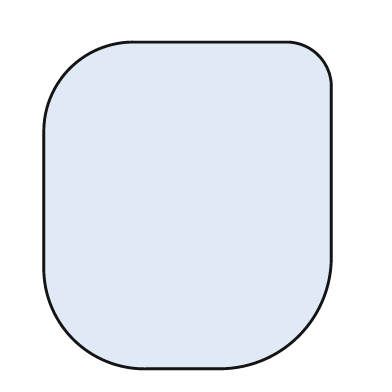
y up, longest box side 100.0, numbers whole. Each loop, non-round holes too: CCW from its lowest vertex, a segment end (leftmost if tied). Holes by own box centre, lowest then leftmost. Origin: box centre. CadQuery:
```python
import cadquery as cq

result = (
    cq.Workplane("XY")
    .moveTo(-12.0, -50.0)
    .lineTo(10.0, -50.0)
    .threePointArc((34.0, -40.0), (44.0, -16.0))
    .lineTo(44.0, 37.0)
    .threePointArc((40.0, 46.0), (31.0, 50.0))
    .lineTo(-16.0, 50.0)
    .threePointArc((-36.0, 42.0), (-44.0, 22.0))
    .lineTo(-44.0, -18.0)
    .threePointArc((-35.0, -41.0), (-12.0, -50.0))
    .close()
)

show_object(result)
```